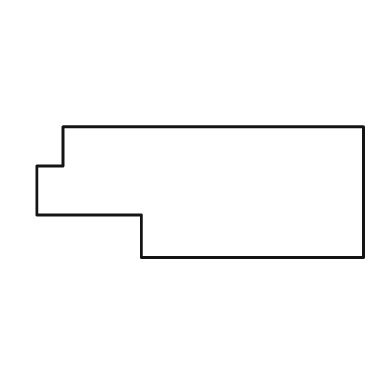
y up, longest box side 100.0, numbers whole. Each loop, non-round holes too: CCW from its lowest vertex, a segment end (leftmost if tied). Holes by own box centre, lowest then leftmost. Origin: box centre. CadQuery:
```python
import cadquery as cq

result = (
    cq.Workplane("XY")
    .moveTo(-18.0, -20.0)
    .lineTo(50.0, -20.0)
    .lineTo(50.0, 20.0)
    .lineTo(-42.0, 20.0)
    .lineTo(-42.0, 8.0)
    .lineTo(-50.0, 8.0)
    .lineTo(-50.0, -7.0)
    .lineTo(-18.0, -7.0)
    .close()
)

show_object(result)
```